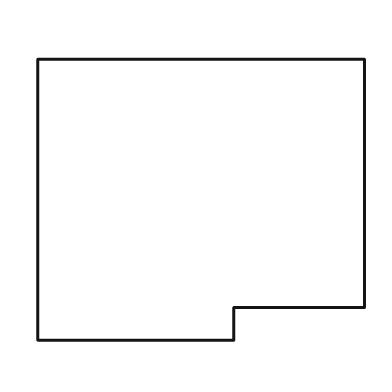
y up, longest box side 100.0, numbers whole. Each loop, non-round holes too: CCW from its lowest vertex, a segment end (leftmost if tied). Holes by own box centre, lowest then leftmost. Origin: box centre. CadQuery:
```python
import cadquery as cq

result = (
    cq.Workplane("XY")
    .moveTo(-50.0, -43.0)
    .lineTo(10.0, -43.0)
    .lineTo(10.0, -33.0)
    .lineTo(50.0, -33.0)
    .lineTo(50.0, 43.0)
    .lineTo(-50.0, 43.0)
    .close()
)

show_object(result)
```